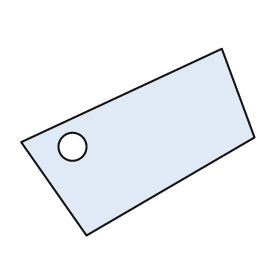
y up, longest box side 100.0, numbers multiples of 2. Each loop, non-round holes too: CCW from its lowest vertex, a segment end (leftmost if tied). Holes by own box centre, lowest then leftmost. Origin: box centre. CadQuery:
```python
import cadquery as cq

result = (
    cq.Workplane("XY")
    .moveTo(-22.0, -40.0)
    .lineTo(50.0, 2.0)
    .lineTo(36.0, 40.0)
    .lineTo(-50.0, 0.0)
    .close()
    .moveTo(-28.0, -2.0)
    .circle(6.0)
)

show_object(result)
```